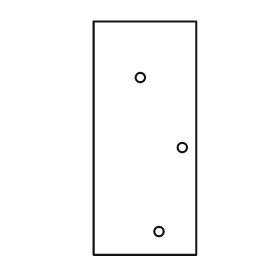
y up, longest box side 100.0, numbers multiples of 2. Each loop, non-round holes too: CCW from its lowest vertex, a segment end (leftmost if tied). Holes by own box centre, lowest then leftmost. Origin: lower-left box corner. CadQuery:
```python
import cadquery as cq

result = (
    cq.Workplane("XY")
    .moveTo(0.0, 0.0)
    .lineTo(44.0, 0.0)
    .lineTo(44.0, 100.0)
    .lineTo(0.0, 100.0)
    .close()
    .moveTo(28.0, 10.0)
    .circle(2.0)
    .moveTo(38.0, 46.0)
    .circle(2.0)
    .moveTo(20.0, 76.0)
    .circle(2.0)
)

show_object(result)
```